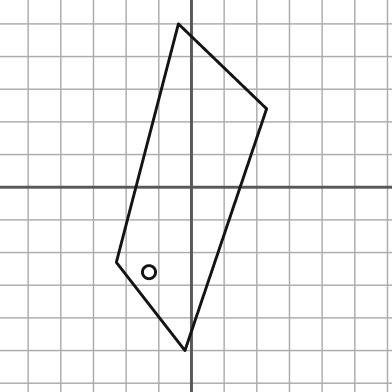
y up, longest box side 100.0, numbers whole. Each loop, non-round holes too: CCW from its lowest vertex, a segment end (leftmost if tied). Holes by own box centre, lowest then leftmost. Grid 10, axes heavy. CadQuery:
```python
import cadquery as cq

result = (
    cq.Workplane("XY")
    .moveTo(-2.0, -50.0)
    .lineTo(23.0, 24.0)
    .lineTo(-4.0, 50.0)
    .lineTo(-23.0, -23.0)
    .close()
    .moveTo(-13.0, -26.0)
    .circle(2.0)
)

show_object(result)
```